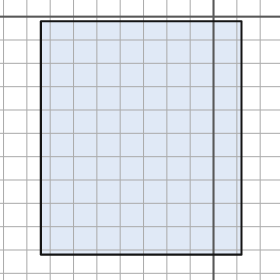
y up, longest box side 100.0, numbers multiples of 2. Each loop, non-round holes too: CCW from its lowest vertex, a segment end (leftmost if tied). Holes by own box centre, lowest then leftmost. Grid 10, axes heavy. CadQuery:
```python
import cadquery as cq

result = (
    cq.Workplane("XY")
    .moveTo(-74.0, -102.0)
    .lineTo(12.0, -102.0)
    .lineTo(12.0, -2.0)
    .lineTo(-74.0, -2.0)
    .close()
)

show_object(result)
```